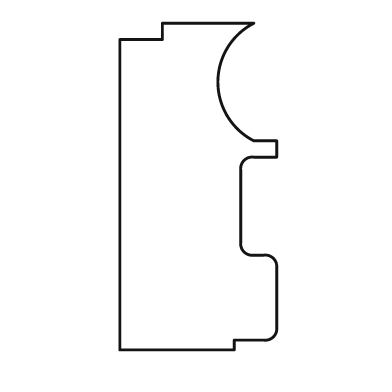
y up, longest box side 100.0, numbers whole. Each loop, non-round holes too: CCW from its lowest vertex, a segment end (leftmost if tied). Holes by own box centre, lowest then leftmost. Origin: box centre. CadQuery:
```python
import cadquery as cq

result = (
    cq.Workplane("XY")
    .moveTo(-24.0, -50.0)
    .lineTo(11.0, -50.0)
    .lineTo(11.0, -47.0)
    .lineTo(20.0, -47.0)
    .threePointArc((23.0, -46.0), (24.0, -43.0))
    .lineTo(24.0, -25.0)
    .threePointArc((23.0, -22.0), (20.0, -21.0))
    .lineTo(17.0, -21.0)
    .threePointArc((14.0, -20.0), (13.0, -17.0))
    .lineTo(13.0, 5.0)
    .threePointArc((14.0, 8.0), (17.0, 9.0))
    .lineTo(24.0, 9.0)
    .lineTo(24.0, 14.0)
    .lineTo(17.0, 14.0)
    .threePointArc((6.0, 32.0), (17.0, 50.0))
    .lineTo(-11.0, 50.0)
    .lineTo(-11.0, 45.0)
    .lineTo(-24.0, 45.0)
    .close()
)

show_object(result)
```